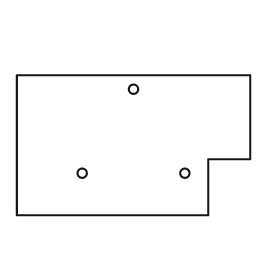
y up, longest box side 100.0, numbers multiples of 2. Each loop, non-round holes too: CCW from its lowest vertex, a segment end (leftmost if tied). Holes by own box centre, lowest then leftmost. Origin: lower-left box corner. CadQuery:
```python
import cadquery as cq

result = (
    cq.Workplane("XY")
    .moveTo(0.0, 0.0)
    .lineTo(82.0, 0.0)
    .lineTo(82.0, 24.0)
    .lineTo(100.0, 24.0)
    .lineTo(100.0, 60.0)
    .lineTo(0.0, 60.0)
    .close()
    .moveTo(28.0, 18.0)
    .circle(2.0)
    .moveTo(72.0, 18.0)
    .circle(2.0)
    .moveTo(50.0, 54.0)
    .circle(2.0)
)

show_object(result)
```